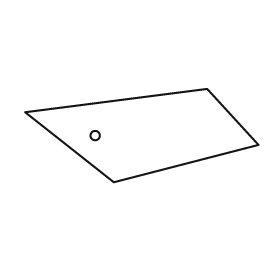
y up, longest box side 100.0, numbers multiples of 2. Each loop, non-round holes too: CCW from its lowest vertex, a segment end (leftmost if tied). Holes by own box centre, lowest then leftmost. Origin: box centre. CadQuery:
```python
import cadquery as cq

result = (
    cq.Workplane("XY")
    .moveTo(-12.0, -20.0)
    .lineTo(50.0, -4.0)
    .lineTo(28.0, 20.0)
    .lineTo(-50.0, 10.0)
    .close()
    .moveTo(-20.0, 0.0)
    .circle(2.0)
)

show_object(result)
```